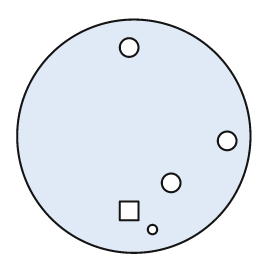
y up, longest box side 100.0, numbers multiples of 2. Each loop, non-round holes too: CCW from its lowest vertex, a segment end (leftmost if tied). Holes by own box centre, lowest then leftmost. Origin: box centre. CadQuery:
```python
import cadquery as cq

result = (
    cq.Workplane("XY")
    .moveTo(0.0, 0.0)
    .circle(50.0)
    .moveTo(8.0, -40.0)
    .circle(2.0)
    .moveTo(-6.0, -36.0)
    .lineTo(2.0, -36.0)
    .lineTo(2.0, -28.0)
    .lineTo(-6.0, -28.0)
    .close()
    .moveTo(16.0, -20.0)
    .circle(4.0)
    .moveTo(40.0, -2.0)
    .circle(4.0)
    .moveTo(-2.0, 38.0)
    .circle(4.0)
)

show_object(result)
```